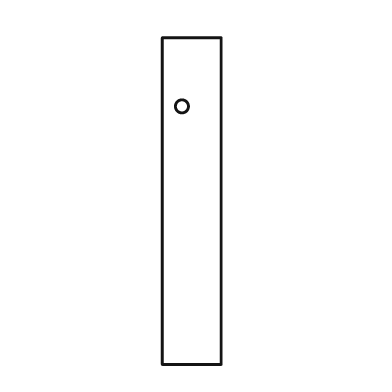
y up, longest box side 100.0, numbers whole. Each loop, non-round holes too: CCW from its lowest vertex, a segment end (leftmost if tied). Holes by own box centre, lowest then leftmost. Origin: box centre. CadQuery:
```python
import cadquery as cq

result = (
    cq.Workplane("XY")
    .moveTo(-9.0, -50.0)
    .lineTo(9.0, -50.0)
    .lineTo(9.0, 50.0)
    .lineTo(-9.0, 50.0)
    .close()
    .moveTo(-3.0, 29.0)
    .circle(2.0)
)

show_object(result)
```